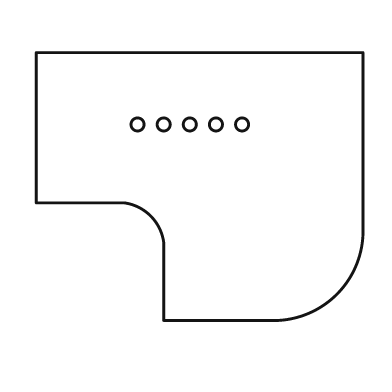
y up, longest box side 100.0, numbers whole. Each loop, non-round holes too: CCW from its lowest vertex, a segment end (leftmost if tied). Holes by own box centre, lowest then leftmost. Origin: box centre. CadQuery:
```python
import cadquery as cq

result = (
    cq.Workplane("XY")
    .moveTo(-11.0, -41.0)
    .lineTo(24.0, -41.0)
    .threePointArc((42.0, -33.0), (50.0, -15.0))
    .lineTo(50.0, 41.0)
    .lineTo(-50.0, 41.0)
    .lineTo(-50.0, -5.0)
    .lineTo(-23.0, -5.0)
    .threePointArc((-15.0, -9.0), (-11.0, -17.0))
    .close()
    .moveTo(-19.0, 19.0)
    .circle(2.0)
    .moveTo(-11.0, 19.0)
    .circle(2.0)
    .moveTo(-3.0, 19.0)
    .circle(2.0)
    .moveTo(5.0, 19.0)
    .circle(2.0)
    .moveTo(13.0, 19.0)
    .circle(2.0)
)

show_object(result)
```